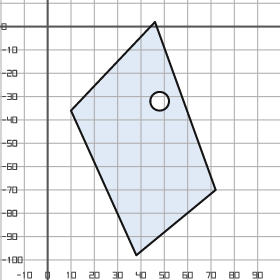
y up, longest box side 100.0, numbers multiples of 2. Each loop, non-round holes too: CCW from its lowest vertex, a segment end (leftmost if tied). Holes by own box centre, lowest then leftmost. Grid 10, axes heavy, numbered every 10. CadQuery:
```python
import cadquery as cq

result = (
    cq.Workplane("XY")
    .moveTo(38.0, -98.0)
    .lineTo(72.0, -70.0)
    .lineTo(46.0, 2.0)
    .lineTo(10.0, -36.0)
    .close()
    .moveTo(48.0, -32.0)
    .circle(4.0)
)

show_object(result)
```